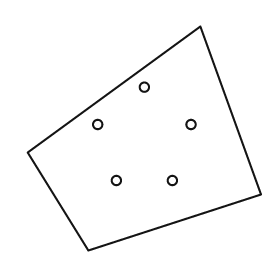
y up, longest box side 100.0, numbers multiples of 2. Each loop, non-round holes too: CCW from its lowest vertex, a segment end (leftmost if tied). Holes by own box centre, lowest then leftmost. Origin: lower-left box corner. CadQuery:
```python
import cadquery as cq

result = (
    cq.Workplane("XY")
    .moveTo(26.0, 0.0)
    .lineTo(100.0, 24.0)
    .lineTo(74.0, 96.0)
    .lineTo(0.0, 42.0)
    .close()
    .moveTo(38.0, 30.0)
    .circle(2.0)
    .moveTo(62.0, 30.0)
    .circle(2.0)
    .moveTo(30.0, 54.0)
    .circle(2.0)
    .moveTo(70.0, 54.0)
    .circle(2.0)
    .moveTo(50.0, 70.0)
    .circle(2.0)
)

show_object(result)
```